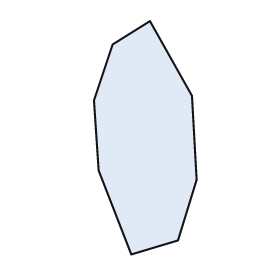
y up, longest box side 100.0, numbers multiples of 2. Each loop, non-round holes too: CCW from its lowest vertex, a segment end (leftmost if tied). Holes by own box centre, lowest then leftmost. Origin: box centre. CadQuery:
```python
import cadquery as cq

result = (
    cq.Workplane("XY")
    .moveTo(-6.0, -50.0)
    .lineTo(14.0, -44.0)
    .lineTo(22.0, -18.0)
    .lineTo(20.0, 18.0)
    .lineTo(2.0, 50.0)
    .lineTo(-14.0, 40.0)
    .lineTo(-22.0, 16.0)
    .lineTo(-20.0, -14.0)
    .close()
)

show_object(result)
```